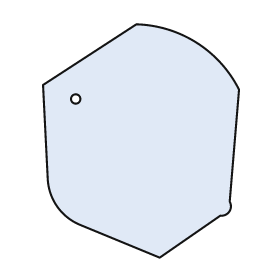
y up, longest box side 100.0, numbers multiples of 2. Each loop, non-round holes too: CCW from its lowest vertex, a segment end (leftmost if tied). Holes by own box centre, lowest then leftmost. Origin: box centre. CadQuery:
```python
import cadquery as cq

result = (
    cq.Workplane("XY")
    .moveTo(8.0, -50.0)
    .lineTo(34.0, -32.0)
    .threePointArc((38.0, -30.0), (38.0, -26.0))
    .lineTo(42.0, 22.0)
    .threePointArc((24.0, 42.0), (-2.0, 50.0))
    .lineTo(-42.0, 24.0)
    .lineTo(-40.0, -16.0)
    .threePointArc((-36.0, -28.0), (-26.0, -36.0))
    .close()
    .moveTo(-28.0, 18.0)
    .circle(2.0)
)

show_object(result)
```